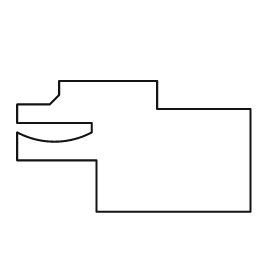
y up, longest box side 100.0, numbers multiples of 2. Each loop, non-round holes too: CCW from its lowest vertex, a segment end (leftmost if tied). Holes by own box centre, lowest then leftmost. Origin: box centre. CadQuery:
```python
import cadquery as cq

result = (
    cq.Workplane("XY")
    .moveTo(-16.0, -28.0)
    .lineTo(50.0, -28.0)
    .lineTo(50.0, 16.0)
    .lineTo(10.0, 16.0)
    .lineTo(10.0, 28.0)
    .lineTo(-32.0, 28.0)
    .lineTo(-32.0, 22.0)
    .lineTo(-36.0, 18.0)
    .lineTo(-50.0, 18.0)
    .lineTo(-50.0, 10.0)
    .lineTo(-18.0, 10.0)
    .lineTo(-18.0, 6.0)
    .threePointArc((-34.0, 2.0), (-50.0, 6.0))
    .lineTo(-50.0, -6.0)
    .lineTo(-16.0, -6.0)
    .close()
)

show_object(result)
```